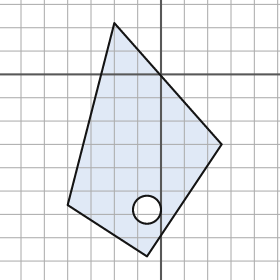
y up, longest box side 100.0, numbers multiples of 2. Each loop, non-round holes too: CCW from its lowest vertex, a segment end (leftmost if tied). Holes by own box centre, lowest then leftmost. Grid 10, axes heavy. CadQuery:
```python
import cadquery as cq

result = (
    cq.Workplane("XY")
    .moveTo(-6.0, -78.0)
    .lineTo(26.0, -30.0)
    .lineTo(-20.0, 22.0)
    .lineTo(-40.0, -56.0)
    .close()
    .moveTo(-6.0, -58.0)
    .circle(6.0)
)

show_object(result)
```